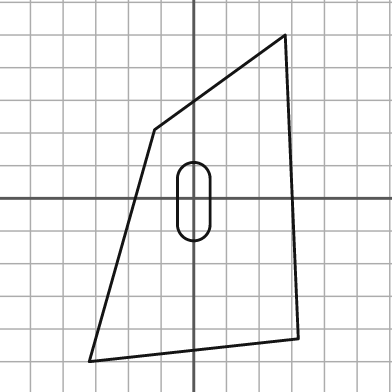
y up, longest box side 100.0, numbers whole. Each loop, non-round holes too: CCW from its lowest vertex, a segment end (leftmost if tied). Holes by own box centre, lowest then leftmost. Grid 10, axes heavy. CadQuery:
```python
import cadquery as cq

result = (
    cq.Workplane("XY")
    .moveTo(-32.0, -50.0)
    .lineTo(32.0, -43.0)
    .lineTo(28.0, 50.0)
    .lineTo(-12.0, 21.0)
    .close()
    .moveTo(-5.0, -8.0)
    .threePointArc((0.0, -13.0), (5.0, -8.0))
    .lineTo(5.0, 6.0)
    .threePointArc((0.0, 11.0), (-5.0, 6.0))
    .close()
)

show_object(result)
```